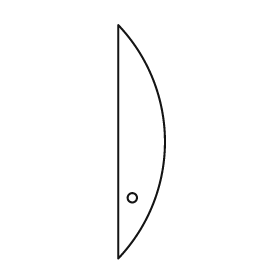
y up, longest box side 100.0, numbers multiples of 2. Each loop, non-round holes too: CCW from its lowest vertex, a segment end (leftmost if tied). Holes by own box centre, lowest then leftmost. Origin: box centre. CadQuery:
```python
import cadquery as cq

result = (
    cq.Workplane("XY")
    .moveTo(-10.0, -50.0)
    .threePointArc((10.0, 0.0), (-10.0, 50.0))
    .close()
    .moveTo(-4.0, -24.0)
    .circle(2.0)
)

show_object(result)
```